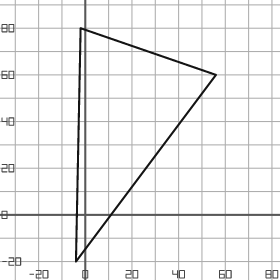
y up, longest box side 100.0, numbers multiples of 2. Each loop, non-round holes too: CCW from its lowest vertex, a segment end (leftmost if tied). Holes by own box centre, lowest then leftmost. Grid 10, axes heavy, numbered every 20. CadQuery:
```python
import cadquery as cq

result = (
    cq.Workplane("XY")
    .moveTo(-4.0, -20.0)
    .lineTo(56.0, 60.0)
    .lineTo(-2.0, 80.0)
    .close()
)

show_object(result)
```